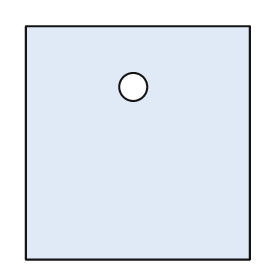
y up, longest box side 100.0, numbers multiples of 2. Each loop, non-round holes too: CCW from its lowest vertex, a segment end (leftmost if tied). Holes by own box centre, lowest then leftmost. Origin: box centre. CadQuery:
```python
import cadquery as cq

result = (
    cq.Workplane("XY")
    .moveTo(-48.0, -50.0)
    .lineTo(48.0, -50.0)
    .lineTo(48.0, 50.0)
    .lineTo(-48.0, 50.0)
    .close()
    .moveTo(-2.0, 24.0)
    .circle(6.0)
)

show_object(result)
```